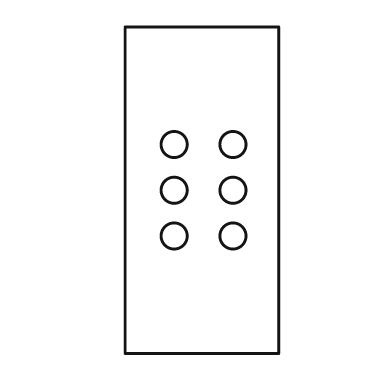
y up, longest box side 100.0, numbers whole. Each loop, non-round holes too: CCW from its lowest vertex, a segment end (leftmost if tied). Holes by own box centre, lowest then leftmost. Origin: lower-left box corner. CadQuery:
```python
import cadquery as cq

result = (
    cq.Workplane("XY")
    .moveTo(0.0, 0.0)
    .lineTo(47.0, 0.0)
    .lineTo(47.0, 100.0)
    .lineTo(0.0, 100.0)
    .close()
    .moveTo(15.0, 36.0)
    .circle(4.0)
    .moveTo(33.0, 36.0)
    .circle(4.0)
    .moveTo(15.0, 50.0)
    .circle(4.0)
    .moveTo(33.0, 50.0)
    .circle(4.0)
    .moveTo(15.0, 64.0)
    .circle(4.0)
    .moveTo(33.0, 64.0)
    .circle(4.0)
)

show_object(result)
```